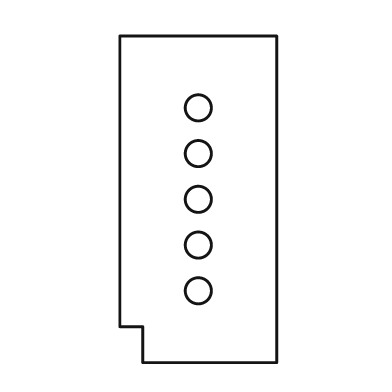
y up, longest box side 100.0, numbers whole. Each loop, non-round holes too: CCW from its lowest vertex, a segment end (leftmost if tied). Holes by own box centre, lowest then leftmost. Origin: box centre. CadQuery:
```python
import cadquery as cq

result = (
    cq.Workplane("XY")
    .moveTo(-17.0, -50.0)
    .lineTo(24.0, -50.0)
    .lineTo(24.0, 50.0)
    .lineTo(-24.0, 50.0)
    .lineTo(-24.0, -39.0)
    .lineTo(-17.0, -39.0)
    .close()
    .moveTo(0.0, -28.0)
    .circle(4.0)
    .moveTo(0.0, -14.0)
    .circle(4.0)
    .moveTo(0.0, 0.0)
    .circle(4.0)
    .moveTo(0.0, 14.0)
    .circle(4.0)
    .moveTo(0.0, 28.0)
    .circle(4.0)
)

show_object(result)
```